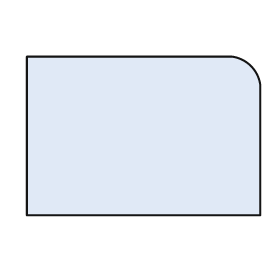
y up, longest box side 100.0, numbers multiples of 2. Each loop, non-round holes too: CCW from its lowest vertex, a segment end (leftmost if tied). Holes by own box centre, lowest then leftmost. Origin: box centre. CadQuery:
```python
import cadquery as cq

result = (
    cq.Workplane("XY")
    .moveTo(-50.0, -34.0)
    .lineTo(50.0, -34.0)
    .lineTo(50.0, 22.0)
    .threePointArc((46.0, 30.0), (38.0, 34.0))
    .lineTo(-50.0, 34.0)
    .close()
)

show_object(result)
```